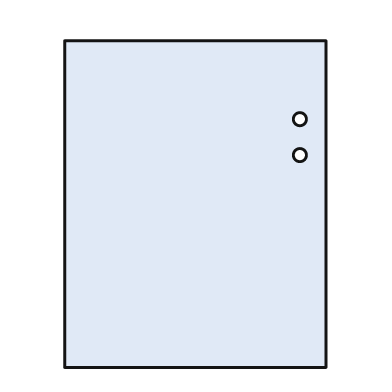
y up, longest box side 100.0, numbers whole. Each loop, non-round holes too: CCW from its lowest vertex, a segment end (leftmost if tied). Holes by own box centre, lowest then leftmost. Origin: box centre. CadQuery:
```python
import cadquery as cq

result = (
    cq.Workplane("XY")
    .moveTo(-40.0, -50.0)
    .lineTo(40.0, -50.0)
    .lineTo(40.0, 50.0)
    .lineTo(-40.0, 50.0)
    .close()
    .moveTo(32.0, 15.0)
    .circle(2.0)
    .moveTo(32.0, 26.0)
    .circle(2.0)
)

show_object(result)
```